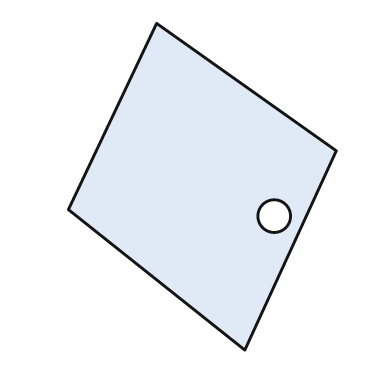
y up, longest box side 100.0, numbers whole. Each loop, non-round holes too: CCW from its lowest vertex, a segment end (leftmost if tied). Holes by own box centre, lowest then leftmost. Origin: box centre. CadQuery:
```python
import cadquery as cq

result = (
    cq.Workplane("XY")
    .moveTo(13.0, -50.0)
    .lineTo(41.0, 11.0)
    .lineTo(-14.0, 50.0)
    .lineTo(-41.0, -7.0)
    .close()
    .moveTo(22.0, -9.0)
    .circle(5.0)
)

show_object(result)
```